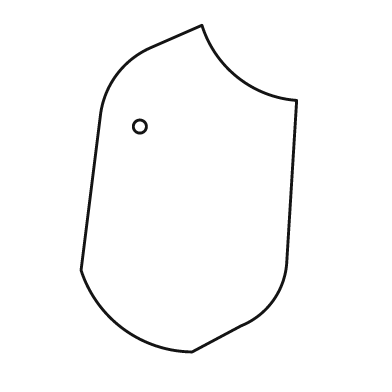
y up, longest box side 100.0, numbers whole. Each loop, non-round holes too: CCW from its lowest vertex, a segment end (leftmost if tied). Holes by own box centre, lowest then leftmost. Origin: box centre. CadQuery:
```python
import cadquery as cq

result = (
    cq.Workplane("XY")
    .moveTo(1.0, -50.0)
    .lineTo(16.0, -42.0)
    .threePointArc((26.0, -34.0), (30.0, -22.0))
    .lineTo(33.0, 27.0)
    .threePointArc((15.0, 34.0), (4.0, 50.0))
    .lineTo(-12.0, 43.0)
    .threePointArc((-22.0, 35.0), (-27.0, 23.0))
    .lineTo(-33.0, -25.0)
    .threePointArc((-20.0, -43.0), (1.0, -50.0))
    .close()
    .moveTo(-15.0, 19.0)
    .circle(2.0)
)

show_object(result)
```